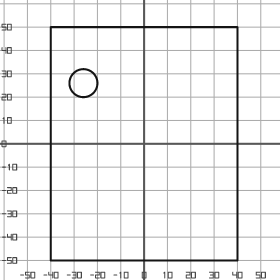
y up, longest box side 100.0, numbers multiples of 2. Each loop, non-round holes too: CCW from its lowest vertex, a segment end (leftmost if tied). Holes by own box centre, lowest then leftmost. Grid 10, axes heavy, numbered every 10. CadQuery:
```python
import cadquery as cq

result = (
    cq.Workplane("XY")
    .moveTo(-40.0, -50.0)
    .lineTo(40.0, -50.0)
    .lineTo(40.0, 50.0)
    .lineTo(-40.0, 50.0)
    .close()
    .moveTo(-26.0, 26.0)
    .circle(6.0)
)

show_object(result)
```